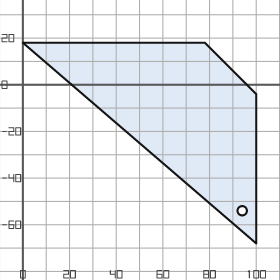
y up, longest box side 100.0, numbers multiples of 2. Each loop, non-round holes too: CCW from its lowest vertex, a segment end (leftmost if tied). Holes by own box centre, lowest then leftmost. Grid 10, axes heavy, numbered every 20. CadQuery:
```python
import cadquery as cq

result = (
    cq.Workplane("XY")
    .moveTo(100.0, -68.0)
    .lineTo(100.0, -4.0)
    .lineTo(78.0, 18.0)
    .lineTo(0.0, 18.0)
    .close()
    .moveTo(94.0, -54.0)
    .circle(2.0)
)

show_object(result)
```